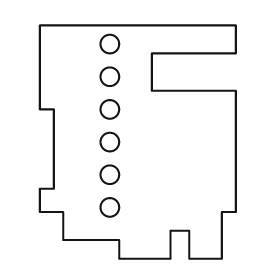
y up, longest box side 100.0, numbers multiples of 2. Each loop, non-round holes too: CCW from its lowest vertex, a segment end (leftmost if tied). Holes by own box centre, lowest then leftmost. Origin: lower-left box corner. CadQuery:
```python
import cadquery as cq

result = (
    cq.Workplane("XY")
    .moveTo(34.0, 0.0)
    .lineTo(56.0, 0.0)
    .lineTo(56.0, 12.0)
    .lineTo(64.0, 12.0)
    .lineTo(64.0, 0.0)
    .lineTo(78.0, 0.0)
    .lineTo(78.0, 20.0)
    .lineTo(84.0, 20.0)
    .lineTo(84.0, 72.0)
    .lineTo(48.0, 72.0)
    .lineTo(48.0, 88.0)
    .lineTo(84.0, 88.0)
    .lineTo(84.0, 100.0)
    .lineTo(0.0, 100.0)
    .lineTo(0.0, 64.0)
    .lineTo(6.0, 64.0)
    .lineTo(6.0, 30.0)
    .lineTo(0.0, 30.0)
    .lineTo(0.0, 20.0)
    .lineTo(10.0, 20.0)
    .lineTo(10.0, 8.0)
    .lineTo(34.0, 8.0)
    .close()
    .moveTo(30.0, 22.0)
    .circle(4.0)
    .moveTo(30.0, 36.0)
    .circle(4.0)
    .moveTo(30.0, 50.0)
    .circle(4.0)
    .moveTo(30.0, 64.0)
    .circle(4.0)
    .moveTo(30.0, 78.0)
    .circle(4.0)
    .moveTo(30.0, 92.0)
    .circle(4.0)
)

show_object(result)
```